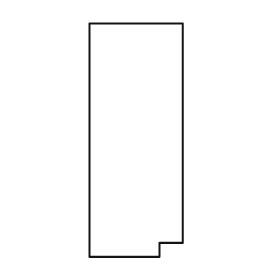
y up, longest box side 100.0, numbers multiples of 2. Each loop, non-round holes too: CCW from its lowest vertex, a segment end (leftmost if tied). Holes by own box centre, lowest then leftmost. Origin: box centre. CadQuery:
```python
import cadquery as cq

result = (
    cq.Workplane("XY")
    .moveTo(-20.0, -50.0)
    .lineTo(10.0, -50.0)
    .lineTo(10.0, -44.0)
    .lineTo(20.0, -44.0)
    .lineTo(20.0, 50.0)
    .lineTo(-20.0, 50.0)
    .close()
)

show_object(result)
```